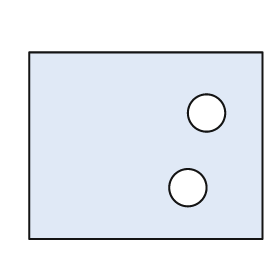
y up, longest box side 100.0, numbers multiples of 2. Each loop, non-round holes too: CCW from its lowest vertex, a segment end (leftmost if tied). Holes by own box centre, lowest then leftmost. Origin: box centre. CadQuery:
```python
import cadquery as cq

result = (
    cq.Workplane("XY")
    .moveTo(-50.0, -40.0)
    .lineTo(50.0, -40.0)
    .lineTo(50.0, 40.0)
    .lineTo(-50.0, 40.0)
    .close()
    .moveTo(18.0, -18.0)
    .circle(8.0)
    .moveTo(26.0, 14.0)
    .circle(8.0)
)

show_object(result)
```